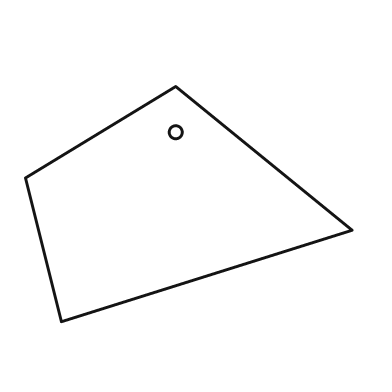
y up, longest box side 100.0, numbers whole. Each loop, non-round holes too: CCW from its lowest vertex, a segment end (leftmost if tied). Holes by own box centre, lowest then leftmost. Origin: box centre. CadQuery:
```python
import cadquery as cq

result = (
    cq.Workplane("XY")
    .moveTo(-39.0, -36.0)
    .lineTo(50.0, -8.0)
    .lineTo(-4.0, 36.0)
    .lineTo(-50.0, 8.0)
    .close()
    .moveTo(-4.0, 22.0)
    .circle(2.0)
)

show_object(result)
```